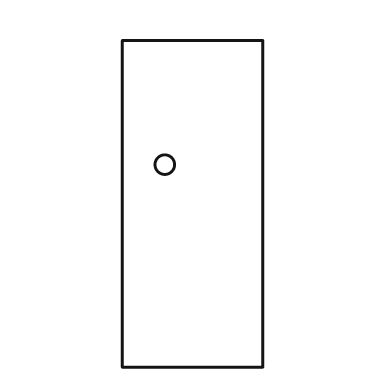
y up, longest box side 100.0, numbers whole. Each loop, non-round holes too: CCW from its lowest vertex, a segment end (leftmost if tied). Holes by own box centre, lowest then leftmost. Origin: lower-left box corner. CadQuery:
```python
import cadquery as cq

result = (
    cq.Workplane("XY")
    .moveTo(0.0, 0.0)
    .lineTo(43.0, 0.0)
    .lineTo(43.0, 100.0)
    .lineTo(0.0, 100.0)
    .close()
    .moveTo(13.0, 62.0)
    .circle(3.0)
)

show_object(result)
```